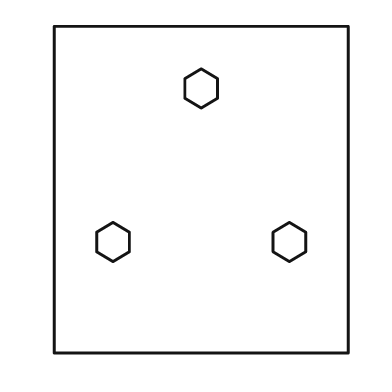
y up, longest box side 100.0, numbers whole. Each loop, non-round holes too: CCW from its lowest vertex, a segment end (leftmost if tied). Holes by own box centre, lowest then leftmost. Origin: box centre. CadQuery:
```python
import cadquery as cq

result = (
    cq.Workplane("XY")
    .moveTo(-45.0, -50.0)
    .lineTo(45.0, -50.0)
    .lineTo(45.0, 50.0)
    .lineTo(-45.0, 50.0)
    .close()
    .moveTo(-27.0, -22.0)
    .lineTo(-22.0, -19.0)
    .lineTo(-22.0, -13.0)
    .lineTo(-27.0, -10.0)
    .lineTo(-32.0, -13.0)
    .lineTo(-32.0, -19.0)
    .close()
    .moveTo(27.0, -22.0)
    .lineTo(32.0, -19.0)
    .lineTo(32.0, -13.0)
    .lineTo(27.0, -10.0)
    .lineTo(22.0, -13.0)
    .lineTo(22.0, -19.0)
    .close()
    .moveTo(0.0, 25.0)
    .lineTo(5.0, 28.0)
    .lineTo(5.0, 34.0)
    .lineTo(0.0, 37.0)
    .lineTo(-5.0, 34.0)
    .lineTo(-5.0, 28.0)
    .close()
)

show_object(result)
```